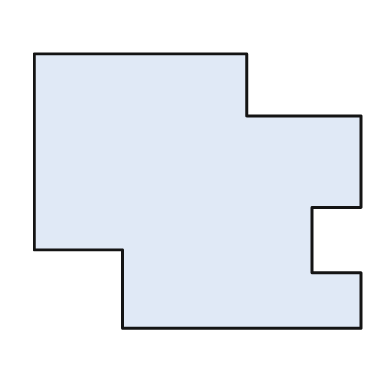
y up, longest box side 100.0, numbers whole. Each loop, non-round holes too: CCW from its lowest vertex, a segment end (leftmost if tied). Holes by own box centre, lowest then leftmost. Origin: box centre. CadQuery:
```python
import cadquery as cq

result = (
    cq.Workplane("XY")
    .moveTo(-23.0, -42.0)
    .lineTo(50.0, -42.0)
    .lineTo(50.0, -25.0)
    .lineTo(35.0, -25.0)
    .lineTo(35.0, -5.0)
    .lineTo(50.0, -5.0)
    .lineTo(50.0, 23.0)
    .lineTo(15.0, 23.0)
    .lineTo(15.0, 42.0)
    .lineTo(-50.0, 42.0)
    .lineTo(-50.0, -18.0)
    .lineTo(-23.0, -18.0)
    .close()
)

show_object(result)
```